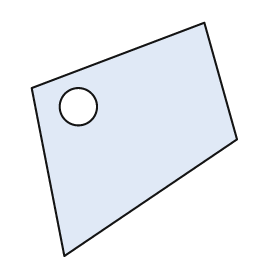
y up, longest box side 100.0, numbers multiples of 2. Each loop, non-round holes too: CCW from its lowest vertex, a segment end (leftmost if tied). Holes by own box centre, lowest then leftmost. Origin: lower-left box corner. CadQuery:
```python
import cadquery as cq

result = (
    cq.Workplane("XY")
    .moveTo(14.0, 0.0)
    .lineTo(88.0, 50.0)
    .lineTo(74.0, 100.0)
    .lineTo(0.0, 72.0)
    .close()
    .moveTo(20.0, 64.0)
    .circle(8.0)
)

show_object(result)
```